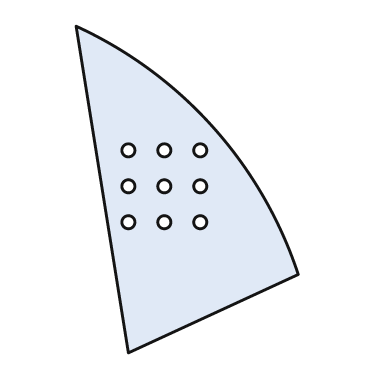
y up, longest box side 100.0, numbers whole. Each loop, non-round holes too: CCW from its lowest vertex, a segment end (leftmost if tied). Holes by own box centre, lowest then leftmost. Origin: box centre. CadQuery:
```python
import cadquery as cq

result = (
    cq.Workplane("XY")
    .moveTo(-18.0, -50.0)
    .lineTo(34.0, -26.0)
    .threePointArc((8.0, 19.0), (-34.0, 50.0))
    .close()
    .moveTo(-18.0, -10.0)
    .circle(2.0)
    .moveTo(-7.0, -10.0)
    .circle(2.0)
    .moveTo(4.0, -10.0)
    .circle(2.0)
    .moveTo(-18.0, 1.0)
    .circle(2.0)
    .moveTo(-7.0, 1.0)
    .circle(2.0)
    .moveTo(4.0, 1.0)
    .circle(2.0)
    .moveTo(-18.0, 12.0)
    .circle(2.0)
    .moveTo(-7.0, 12.0)
    .circle(2.0)
    .moveTo(4.0, 12.0)
    .circle(2.0)
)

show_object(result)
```